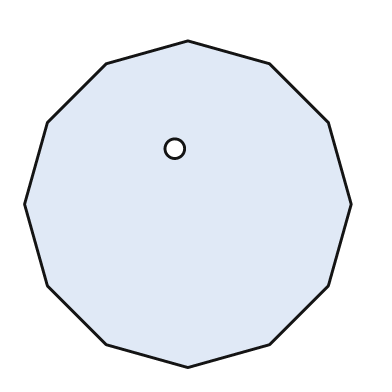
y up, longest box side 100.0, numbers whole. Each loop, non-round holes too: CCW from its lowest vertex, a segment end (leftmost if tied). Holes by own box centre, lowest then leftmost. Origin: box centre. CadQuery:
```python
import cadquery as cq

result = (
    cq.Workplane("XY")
    .moveTo(0.0, -50.0)
    .lineTo(25.0, -43.0)
    .lineTo(43.0, -25.0)
    .lineTo(50.0, 0.0)
    .lineTo(43.0, 25.0)
    .lineTo(25.0, 43.0)
    .lineTo(0.0, 50.0)
    .lineTo(-25.0, 43.0)
    .lineTo(-43.0, 25.0)
    .lineTo(-50.0, 0.0)
    .lineTo(-43.0, -25.0)
    .lineTo(-25.0, -43.0)
    .close()
    .moveTo(-4.0, 17.0)
    .circle(3.0)
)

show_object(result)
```